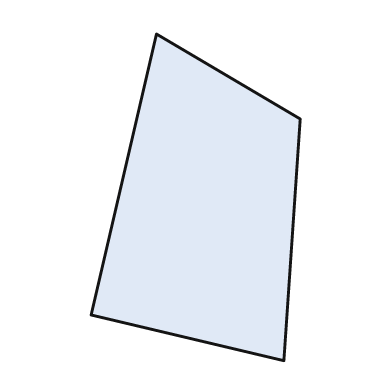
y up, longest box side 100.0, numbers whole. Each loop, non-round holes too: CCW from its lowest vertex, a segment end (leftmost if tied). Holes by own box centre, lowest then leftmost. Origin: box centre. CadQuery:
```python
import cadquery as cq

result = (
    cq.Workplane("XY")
    .moveTo(27.0, -50.0)
    .lineTo(32.0, 24.0)
    .lineTo(-12.0, 50.0)
    .lineTo(-32.0, -36.0)
    .close()
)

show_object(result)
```